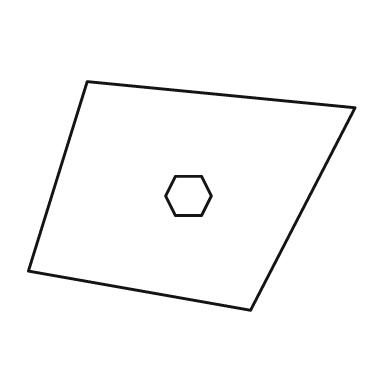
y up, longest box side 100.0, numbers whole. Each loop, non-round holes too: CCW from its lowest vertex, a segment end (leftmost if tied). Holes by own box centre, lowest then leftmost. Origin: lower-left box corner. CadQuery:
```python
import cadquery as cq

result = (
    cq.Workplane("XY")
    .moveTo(68.0, 0.0)
    .lineTo(100.0, 62.0)
    .lineTo(18.0, 70.0)
    .lineTo(0.0, 12.0)
    .close()
    .moveTo(45.0, 29.0)
    .lineTo(53.0, 29.0)
    .lineTo(56.0, 35.0)
    .lineTo(53.0, 41.0)
    .lineTo(45.0, 41.0)
    .lineTo(42.0, 35.0)
    .close()
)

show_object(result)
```